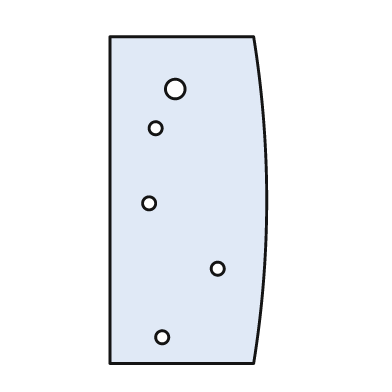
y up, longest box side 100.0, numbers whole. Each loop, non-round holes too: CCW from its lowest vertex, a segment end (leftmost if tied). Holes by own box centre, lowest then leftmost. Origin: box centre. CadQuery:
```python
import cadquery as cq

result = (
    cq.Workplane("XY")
    .moveTo(-24.0, -50.0)
    .lineTo(20.0, -50.0)
    .threePointArc((24.0, 0.0), (20.0, 50.0))
    .lineTo(-24.0, 50.0)
    .close()
    .moveTo(-8.0, -42.0)
    .circle(2.0)
    .moveTo(9.0, -21.0)
    .circle(2.0)
    .moveTo(-12.0, -1.0)
    .circle(2.0)
    .moveTo(-10.0, 22.0)
    .circle(2.0)
    .moveTo(-4.0, 34.0)
    .circle(3.0)
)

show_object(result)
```